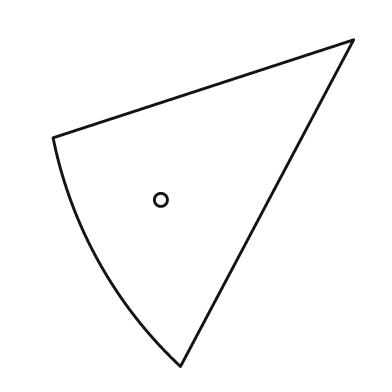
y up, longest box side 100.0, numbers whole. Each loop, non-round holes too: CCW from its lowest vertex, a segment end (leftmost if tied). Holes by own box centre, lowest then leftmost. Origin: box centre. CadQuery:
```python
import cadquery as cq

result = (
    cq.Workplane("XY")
    .moveTo(-7.0, -50.0)
    .lineTo(46.0, 50.0)
    .lineTo(-46.0, 20.0)
    .threePointArc((-32.0, -18.0), (-7.0, -50.0))
    .close()
    .moveTo(-13.0, 1.0)
    .circle(2.0)
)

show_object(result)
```